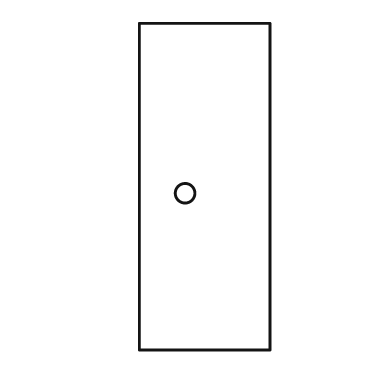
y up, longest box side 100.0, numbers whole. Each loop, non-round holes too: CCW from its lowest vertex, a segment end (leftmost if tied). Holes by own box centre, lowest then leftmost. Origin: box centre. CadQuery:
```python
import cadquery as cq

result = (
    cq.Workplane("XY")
    .moveTo(-20.0, -50.0)
    .lineTo(20.0, -50.0)
    .lineTo(20.0, 50.0)
    .lineTo(-20.0, 50.0)
    .close()
    .moveTo(-6.0, -2.0)
    .circle(3.0)
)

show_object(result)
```